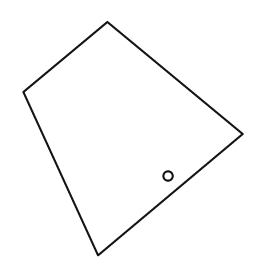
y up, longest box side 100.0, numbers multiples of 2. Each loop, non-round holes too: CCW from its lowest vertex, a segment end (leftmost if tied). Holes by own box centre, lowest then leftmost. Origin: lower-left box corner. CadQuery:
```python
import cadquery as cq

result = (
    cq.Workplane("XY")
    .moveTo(32.0, 0.0)
    .lineTo(94.0, 52.0)
    .lineTo(36.0, 100.0)
    .lineTo(0.0, 70.0)
    .close()
    .moveTo(62.0, 34.0)
    .circle(2.0)
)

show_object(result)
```